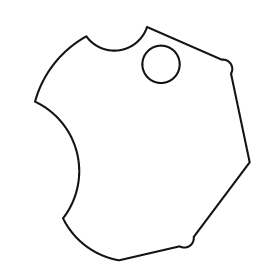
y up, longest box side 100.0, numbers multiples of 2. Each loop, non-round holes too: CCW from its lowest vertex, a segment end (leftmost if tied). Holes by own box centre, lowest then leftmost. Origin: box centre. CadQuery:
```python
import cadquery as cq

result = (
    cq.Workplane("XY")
    .moveTo(-10.0, -50.0)
    .lineTo(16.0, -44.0)
    .threePointArc((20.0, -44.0), (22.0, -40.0))
    .lineTo(46.0, -8.0)
    .lineTo(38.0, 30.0)
    .threePointArc((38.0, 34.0), (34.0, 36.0))
    .lineTo(2.0, 50.0)
    .threePointArc((-10.0, 40.0), (-24.0, 46.0))
    .threePointArc((-38.0, 34.0), (-46.0, 18.0))
    .threePointArc((-28.0, -4.0), (-34.0, -32.0))
    .threePointArc((-24.0, -44.0), (-10.0, -50.0))
    .close()
    .moveTo(8.0, 34.0)
    .circle(8.0)
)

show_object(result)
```